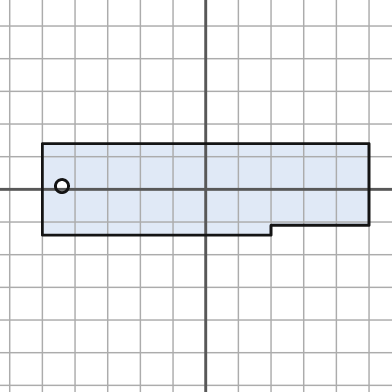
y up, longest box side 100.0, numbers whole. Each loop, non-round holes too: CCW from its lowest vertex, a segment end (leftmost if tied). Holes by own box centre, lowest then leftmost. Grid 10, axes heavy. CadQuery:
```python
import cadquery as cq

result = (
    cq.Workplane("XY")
    .moveTo(-50.0, -14.0)
    .lineTo(20.0, -14.0)
    .lineTo(20.0, -11.0)
    .lineTo(50.0, -11.0)
    .lineTo(50.0, 14.0)
    .lineTo(-50.0, 14.0)
    .close()
    .moveTo(-44.0, 1.0)
    .circle(2.0)
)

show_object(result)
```